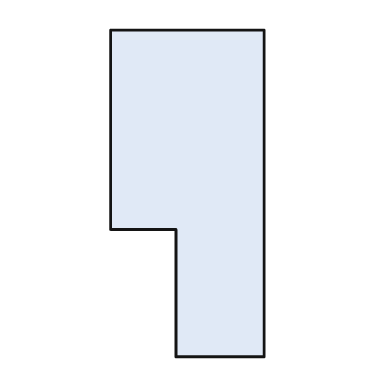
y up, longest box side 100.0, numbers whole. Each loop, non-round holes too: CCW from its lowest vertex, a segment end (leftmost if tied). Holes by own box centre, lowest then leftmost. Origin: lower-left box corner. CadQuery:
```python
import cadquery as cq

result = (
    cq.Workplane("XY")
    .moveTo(20.0, 0.0)
    .lineTo(47.0, 0.0)
    .lineTo(47.0, 100.0)
    .lineTo(0.0, 100.0)
    .lineTo(0.0, 39.0)
    .lineTo(20.0, 39.0)
    .close()
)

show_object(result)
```